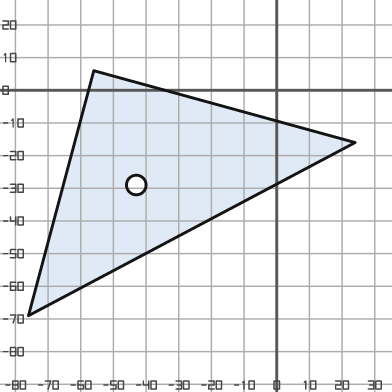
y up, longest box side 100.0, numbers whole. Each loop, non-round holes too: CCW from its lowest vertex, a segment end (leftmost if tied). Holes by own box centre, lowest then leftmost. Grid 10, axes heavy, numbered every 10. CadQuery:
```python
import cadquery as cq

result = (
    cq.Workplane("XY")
    .moveTo(-76.0, -69.0)
    .lineTo(24.0, -16.0)
    .lineTo(-56.0, 6.0)
    .close()
    .moveTo(-43.0, -29.0)
    .circle(3.0)
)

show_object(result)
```